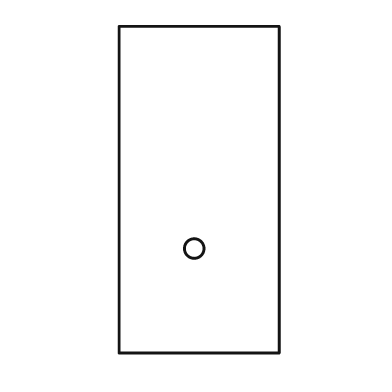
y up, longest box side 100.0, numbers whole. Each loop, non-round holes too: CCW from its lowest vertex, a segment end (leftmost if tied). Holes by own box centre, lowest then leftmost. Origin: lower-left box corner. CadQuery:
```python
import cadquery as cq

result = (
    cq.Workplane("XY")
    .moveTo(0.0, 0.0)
    .lineTo(49.0, 0.0)
    .lineTo(49.0, 100.0)
    .lineTo(0.0, 100.0)
    .close()
    .moveTo(23.0, 32.0)
    .circle(3.0)
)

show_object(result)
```